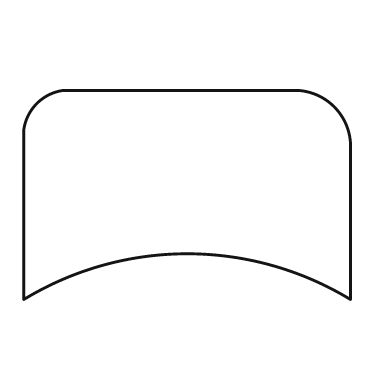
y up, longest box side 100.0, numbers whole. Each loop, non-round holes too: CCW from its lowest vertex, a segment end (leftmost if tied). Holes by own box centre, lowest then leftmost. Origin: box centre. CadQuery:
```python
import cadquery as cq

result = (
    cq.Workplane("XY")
    .moveTo(-50.0, -32.0)
    .threePointArc((0.0, -18.0), (50.0, -32.0))
    .lineTo(50.0, 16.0)
    .threePointArc((45.0, 27.0), (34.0, 32.0))
    .lineTo(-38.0, 32.0)
    .threePointArc((-46.0, 28.0), (-50.0, 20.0))
    .close()
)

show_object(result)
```